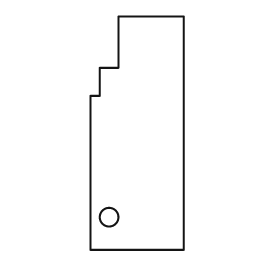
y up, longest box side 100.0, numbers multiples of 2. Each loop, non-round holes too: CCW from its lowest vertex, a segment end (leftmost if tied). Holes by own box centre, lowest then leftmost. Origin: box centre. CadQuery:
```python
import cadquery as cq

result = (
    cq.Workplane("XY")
    .moveTo(-20.0, -50.0)
    .lineTo(20.0, -50.0)
    .lineTo(20.0, 50.0)
    .lineTo(-8.0, 50.0)
    .lineTo(-8.0, 28.0)
    .lineTo(-16.0, 28.0)
    .lineTo(-16.0, 16.0)
    .lineTo(-20.0, 16.0)
    .close()
    .moveTo(-12.0, -36.0)
    .circle(4.0)
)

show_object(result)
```